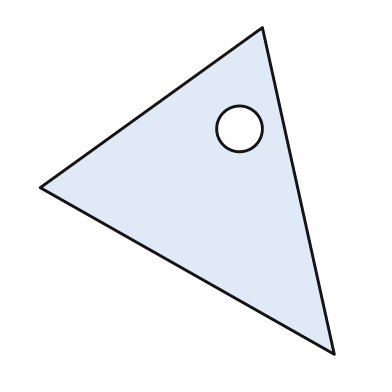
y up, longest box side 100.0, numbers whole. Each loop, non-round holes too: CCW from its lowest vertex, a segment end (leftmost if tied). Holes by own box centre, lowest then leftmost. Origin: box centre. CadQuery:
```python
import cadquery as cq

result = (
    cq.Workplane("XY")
    .moveTo(45.0, -50.0)
    .lineTo(23.0, 50.0)
    .lineTo(-45.0, 1.0)
    .close()
    .moveTo(16.0, 19.0)
    .circle(7.0)
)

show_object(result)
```